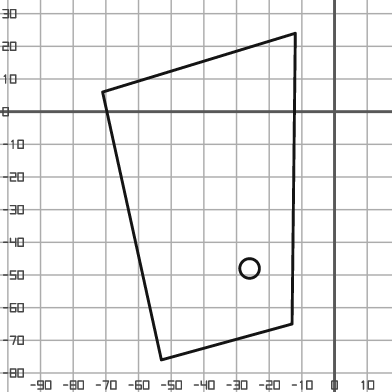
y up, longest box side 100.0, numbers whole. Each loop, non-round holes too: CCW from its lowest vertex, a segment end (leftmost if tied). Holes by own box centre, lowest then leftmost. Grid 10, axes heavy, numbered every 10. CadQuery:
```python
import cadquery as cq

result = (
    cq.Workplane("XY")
    .moveTo(-53.0, -76.0)
    .lineTo(-13.0, -65.0)
    .lineTo(-12.0, 24.0)
    .lineTo(-71.0, 6.0)
    .close()
    .moveTo(-26.0, -48.0)
    .circle(3.0)
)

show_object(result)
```